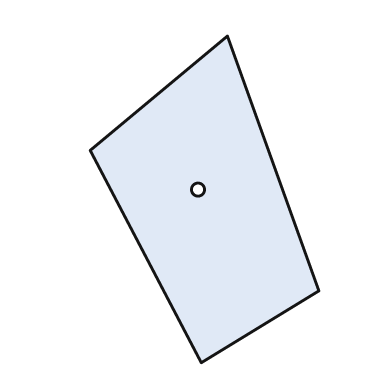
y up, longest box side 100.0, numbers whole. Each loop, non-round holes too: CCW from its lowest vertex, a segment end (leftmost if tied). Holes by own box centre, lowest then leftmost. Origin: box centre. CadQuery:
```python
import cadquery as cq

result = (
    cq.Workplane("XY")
    .moveTo(-1.0, -50.0)
    .lineTo(35.0, -28.0)
    .lineTo(7.0, 50.0)
    .lineTo(-35.0, 15.0)
    .close()
    .moveTo(-2.0, 3.0)
    .circle(2.0)
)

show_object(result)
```